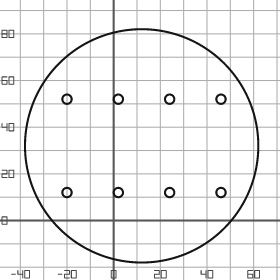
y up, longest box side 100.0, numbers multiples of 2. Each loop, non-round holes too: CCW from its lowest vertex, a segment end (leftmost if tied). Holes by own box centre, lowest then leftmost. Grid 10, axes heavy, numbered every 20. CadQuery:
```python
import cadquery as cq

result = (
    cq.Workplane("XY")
    .moveTo(12.0, 32.0)
    .circle(50.0)
    .moveTo(-20.0, 12.0)
    .circle(2.0)
    .moveTo(2.0, 12.0)
    .circle(2.0)
    .moveTo(24.0, 12.0)
    .circle(2.0)
    .moveTo(46.0, 12.0)
    .circle(2.0)
    .moveTo(-20.0, 52.0)
    .circle(2.0)
    .moveTo(2.0, 52.0)
    .circle(2.0)
    .moveTo(24.0, 52.0)
    .circle(2.0)
    .moveTo(46.0, 52.0)
    .circle(2.0)
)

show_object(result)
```